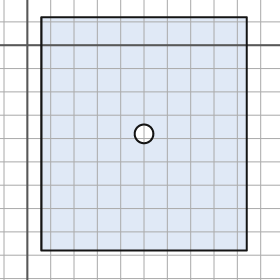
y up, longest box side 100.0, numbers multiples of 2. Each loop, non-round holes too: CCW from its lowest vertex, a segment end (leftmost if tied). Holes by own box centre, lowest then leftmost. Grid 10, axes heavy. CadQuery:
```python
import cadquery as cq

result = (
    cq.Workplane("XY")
    .moveTo(6.0, -88.0)
    .lineTo(94.0, -88.0)
    .lineTo(94.0, 12.0)
    .lineTo(6.0, 12.0)
    .close()
    .moveTo(50.0, -38.0)
    .circle(4.0)
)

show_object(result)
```